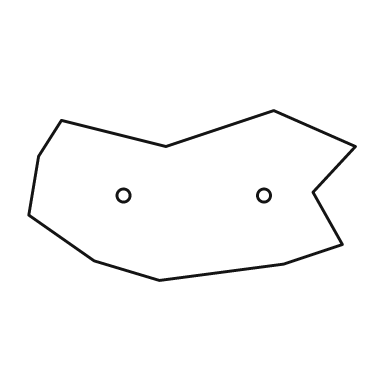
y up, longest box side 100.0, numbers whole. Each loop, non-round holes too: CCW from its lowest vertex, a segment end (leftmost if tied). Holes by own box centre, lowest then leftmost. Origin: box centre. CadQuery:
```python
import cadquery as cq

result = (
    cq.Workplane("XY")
    .moveTo(-10.0, -26.0)
    .lineTo(28.0, -21.0)
    .lineTo(46.0, -15.0)
    .lineTo(37.0, 1.0)
    .lineTo(50.0, 15.0)
    .lineTo(25.0, 26.0)
    .lineTo(-8.0, 15.0)
    .lineTo(-40.0, 23.0)
    .lineTo(-47.0, 12.0)
    .lineTo(-50.0, -6.0)
    .lineTo(-30.0, -20.0)
    .close()
    .moveTo(-21.0, 0.0)
    .circle(2.0)
    .moveTo(22.0, 0.0)
    .circle(2.0)
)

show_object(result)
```